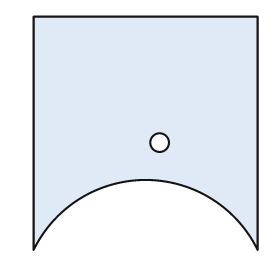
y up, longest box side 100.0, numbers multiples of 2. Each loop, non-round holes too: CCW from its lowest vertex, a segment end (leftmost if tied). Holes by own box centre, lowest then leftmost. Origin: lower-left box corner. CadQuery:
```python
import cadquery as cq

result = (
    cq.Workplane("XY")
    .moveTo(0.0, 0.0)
    .threePointArc((48.0, 30.0), (96.0, 0.0))
    .lineTo(96.0, 100.0)
    .lineTo(0.0, 100.0)
    .close()
    .moveTo(54.0, 46.0)
    .circle(4.0)
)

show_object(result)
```